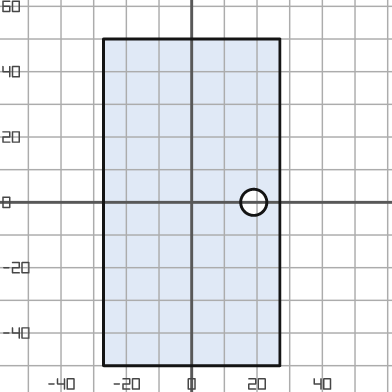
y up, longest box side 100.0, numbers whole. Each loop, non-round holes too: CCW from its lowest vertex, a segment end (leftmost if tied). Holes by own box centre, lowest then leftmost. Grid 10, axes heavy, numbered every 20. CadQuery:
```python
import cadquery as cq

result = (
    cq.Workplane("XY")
    .moveTo(-27.0, -50.0)
    .lineTo(27.0, -50.0)
    .lineTo(27.0, 50.0)
    .lineTo(-27.0, 50.0)
    .close()
    .moveTo(19.0, 0.0)
    .circle(4.0)
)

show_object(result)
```